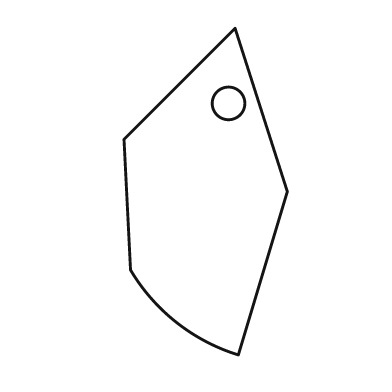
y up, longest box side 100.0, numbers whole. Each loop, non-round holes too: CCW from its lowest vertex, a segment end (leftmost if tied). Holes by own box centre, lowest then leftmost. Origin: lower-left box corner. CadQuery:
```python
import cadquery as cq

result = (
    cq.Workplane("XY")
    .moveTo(35.0, 0.0)
    .lineTo(50.0, 50.0)
    .lineTo(34.0, 100.0)
    .lineTo(0.0, 66.0)
    .lineTo(2.0, 26.0)
    .threePointArc((16.0, 10.0), (35.0, 0.0))
    .close()
    .moveTo(32.0, 77.0)
    .circle(5.0)
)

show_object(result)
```